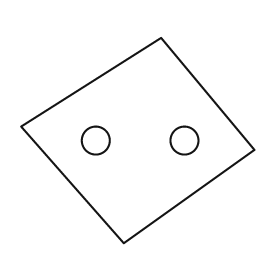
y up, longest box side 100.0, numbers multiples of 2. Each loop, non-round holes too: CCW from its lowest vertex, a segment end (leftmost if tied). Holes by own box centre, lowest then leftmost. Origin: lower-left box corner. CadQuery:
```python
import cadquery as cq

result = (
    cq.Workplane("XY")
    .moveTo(44.0, 0.0)
    .lineTo(100.0, 40.0)
    .lineTo(60.0, 88.0)
    .lineTo(0.0, 50.0)
    .close()
    .moveTo(32.0, 44.0)
    .circle(6.0)
    .moveTo(70.0, 44.0)
    .circle(6.0)
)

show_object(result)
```